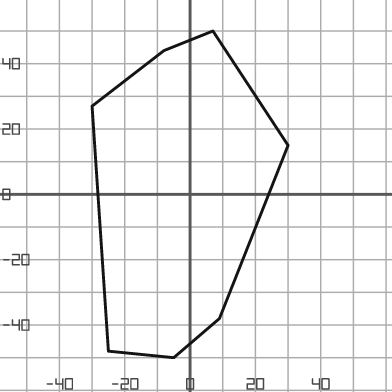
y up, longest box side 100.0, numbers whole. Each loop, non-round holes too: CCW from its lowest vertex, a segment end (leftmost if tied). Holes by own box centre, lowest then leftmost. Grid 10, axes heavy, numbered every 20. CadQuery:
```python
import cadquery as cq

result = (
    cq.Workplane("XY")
    .moveTo(-5.0, -50.0)
    .lineTo(9.0, -38.0)
    .lineTo(30.0, 15.0)
    .lineTo(7.0, 50.0)
    .lineTo(-8.0, 44.0)
    .lineTo(-30.0, 27.0)
    .lineTo(-25.0, -48.0)
    .close()
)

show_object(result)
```